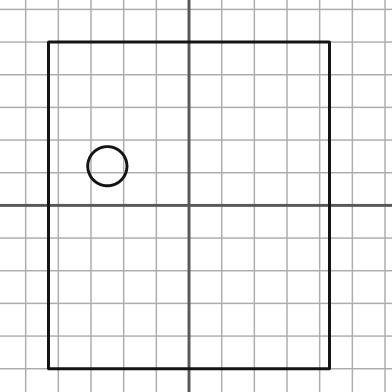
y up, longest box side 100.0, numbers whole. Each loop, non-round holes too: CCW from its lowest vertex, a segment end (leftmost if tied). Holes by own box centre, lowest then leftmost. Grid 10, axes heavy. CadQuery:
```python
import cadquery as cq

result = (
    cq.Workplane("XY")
    .moveTo(-43.0, -50.0)
    .lineTo(43.0, -50.0)
    .lineTo(43.0, 50.0)
    .lineTo(-43.0, 50.0)
    .close()
    .moveTo(-25.0, 12.0)
    .circle(6.0)
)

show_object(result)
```